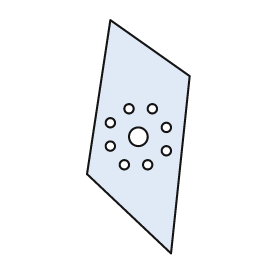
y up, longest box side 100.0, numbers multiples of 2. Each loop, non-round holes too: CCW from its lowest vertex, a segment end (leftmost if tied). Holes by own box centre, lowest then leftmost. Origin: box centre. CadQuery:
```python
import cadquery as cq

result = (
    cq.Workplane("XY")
    .moveTo(14.0, -50.0)
    .lineTo(22.0, 26.0)
    .lineTo(-12.0, 50.0)
    .lineTo(-22.0, -16.0)
    .close()
    .moveTo(-6.0, -12.0)
    .circle(2.0)
    .moveTo(4.0, -12.0)
    .circle(2.0)
    .moveTo(12.0, -6.0)
    .circle(2.0)
    .moveTo(-12.0, -4.0)
    .circle(2.0)
    .moveTo(0.0, 0.0)
    .circle(4.0)
    .moveTo(12.0, 4.0)
    .circle(2.0)
    .moveTo(-12.0, 6.0)
    .circle(2.0)
    .moveTo(-4.0, 12.0)
    .circle(2.0)
    .moveTo(6.0, 12.0)
    .circle(2.0)
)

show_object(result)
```